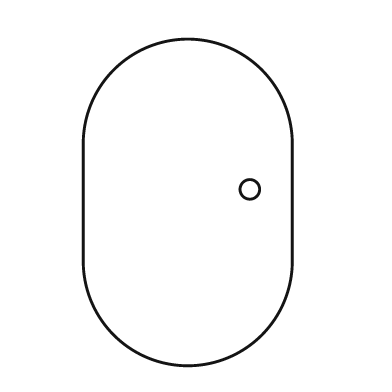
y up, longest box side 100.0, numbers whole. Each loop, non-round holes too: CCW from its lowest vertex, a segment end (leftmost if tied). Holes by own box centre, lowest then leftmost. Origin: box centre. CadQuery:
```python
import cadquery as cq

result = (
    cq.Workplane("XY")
    .moveTo(-32.0, -18.0)
    .threePointArc((0.0, -50.0), (32.0, -18.0))
    .lineTo(32.0, 18.0)
    .threePointArc((0.0, 50.0), (-32.0, 18.0))
    .close()
    .moveTo(19.0, 4.0)
    .circle(3.0)
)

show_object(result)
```